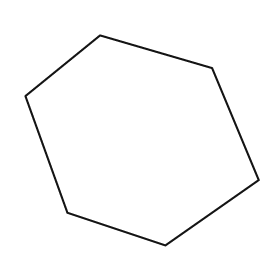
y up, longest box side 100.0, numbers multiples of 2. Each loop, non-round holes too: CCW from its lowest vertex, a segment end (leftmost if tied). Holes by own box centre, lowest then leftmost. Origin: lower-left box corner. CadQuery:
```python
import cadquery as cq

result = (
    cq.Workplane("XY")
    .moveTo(60.0, 0.0)
    .lineTo(100.0, 28.0)
    .lineTo(80.0, 76.0)
    .lineTo(32.0, 90.0)
    .lineTo(0.0, 64.0)
    .lineTo(18.0, 14.0)
    .close()
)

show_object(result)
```